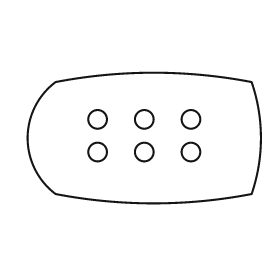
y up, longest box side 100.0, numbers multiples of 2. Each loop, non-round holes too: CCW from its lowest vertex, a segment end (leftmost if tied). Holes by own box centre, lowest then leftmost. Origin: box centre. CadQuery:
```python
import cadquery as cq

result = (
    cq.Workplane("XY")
    .moveTo(-38.0, -24.0)
    .threePointArc((4.0, -28.0), (46.0, -24.0))
    .threePointArc((50.0, 0.0), (46.0, 24.0))
    .threePointArc((4.0, 28.0), (-38.0, 24.0))
    .threePointArc((-50.0, 0.0), (-38.0, -24.0))
    .close()
    .moveTo(-20.0, -6.0)
    .circle(4.0)
    .moveTo(0.0, -6.0)
    .circle(4.0)
    .moveTo(20.0, -6.0)
    .circle(4.0)
    .moveTo(-20.0, 8.0)
    .circle(4.0)
    .moveTo(0.0, 8.0)
    .circle(4.0)
    .moveTo(20.0, 8.0)
    .circle(4.0)
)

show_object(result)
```